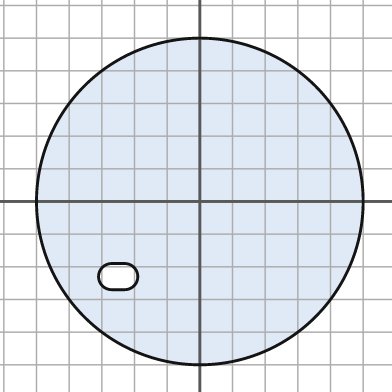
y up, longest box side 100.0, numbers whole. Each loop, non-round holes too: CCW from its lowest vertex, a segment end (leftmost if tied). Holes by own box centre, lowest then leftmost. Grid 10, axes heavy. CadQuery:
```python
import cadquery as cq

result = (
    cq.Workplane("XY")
    .moveTo(0.0, 0.0)
    .circle(50.0)
    .moveTo(-27.0, -27.0)
    .lineTo(-23.0, -27.0)
    .threePointArc((-19.0, -23.0), (-23.0, -19.0))
    .lineTo(-27.0, -19.0)
    .threePointArc((-31.0, -23.0), (-27.0, -27.0))
    .close()
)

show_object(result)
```